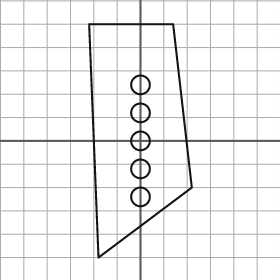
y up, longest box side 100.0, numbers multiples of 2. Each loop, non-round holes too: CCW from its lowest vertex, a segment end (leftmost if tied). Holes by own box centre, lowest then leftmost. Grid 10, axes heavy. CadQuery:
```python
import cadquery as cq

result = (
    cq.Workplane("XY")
    .moveTo(-18.0, -50.0)
    .lineTo(22.0, -20.0)
    .lineTo(14.0, 50.0)
    .lineTo(-22.0, 50.0)
    .close()
    .moveTo(0.0, -24.0)
    .circle(4.0)
    .moveTo(0.0, -12.0)
    .circle(4.0)
    .moveTo(0.0, 0.0)
    .circle(4.0)
    .moveTo(0.0, 12.0)
    .circle(4.0)
    .moveTo(0.0, 24.0)
    .circle(4.0)
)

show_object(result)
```